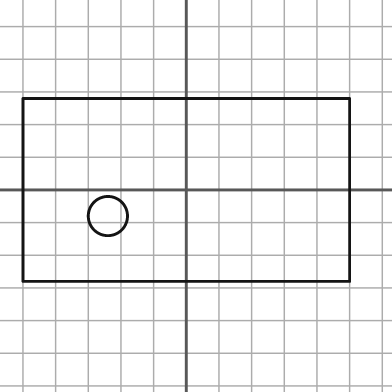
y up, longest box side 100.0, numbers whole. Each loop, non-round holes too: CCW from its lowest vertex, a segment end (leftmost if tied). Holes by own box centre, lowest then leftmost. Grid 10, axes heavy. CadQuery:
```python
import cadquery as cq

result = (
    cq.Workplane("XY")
    .moveTo(-50.0, -28.0)
    .lineTo(50.0, -28.0)
    .lineTo(50.0, 28.0)
    .lineTo(-50.0, 28.0)
    .close()
    .moveTo(-24.0, -8.0)
    .circle(6.0)
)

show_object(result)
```